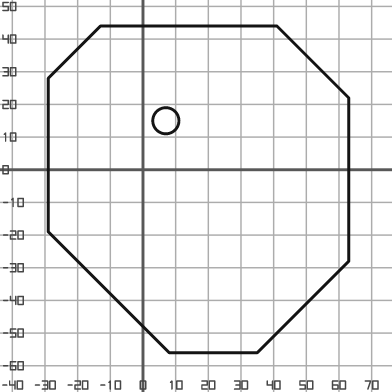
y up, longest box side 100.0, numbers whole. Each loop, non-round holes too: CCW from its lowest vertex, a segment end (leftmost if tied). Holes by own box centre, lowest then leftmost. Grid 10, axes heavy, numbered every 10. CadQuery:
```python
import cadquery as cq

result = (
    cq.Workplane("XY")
    .moveTo(8.0, -56.0)
    .lineTo(35.0, -56.0)
    .lineTo(63.0, -28.0)
    .lineTo(63.0, 22.0)
    .lineTo(41.0, 44.0)
    .lineTo(-13.0, 44.0)
    .lineTo(-29.0, 28.0)
    .lineTo(-29.0, -19.0)
    .close()
    .moveTo(7.0, 15.0)
    .circle(4.0)
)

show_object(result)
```